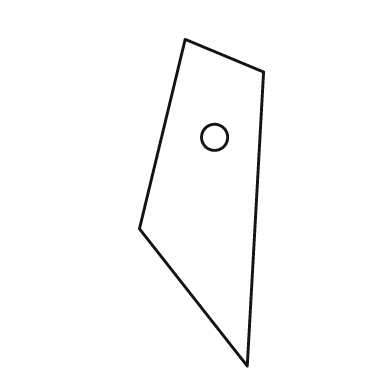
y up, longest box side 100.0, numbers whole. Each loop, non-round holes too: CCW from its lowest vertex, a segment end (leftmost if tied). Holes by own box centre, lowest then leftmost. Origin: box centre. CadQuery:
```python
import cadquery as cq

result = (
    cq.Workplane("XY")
    .moveTo(14.0, -50.0)
    .lineTo(19.0, 40.0)
    .lineTo(-5.0, 50.0)
    .lineTo(-19.0, -8.0)
    .close()
    .moveTo(4.0, 20.0)
    .circle(4.0)
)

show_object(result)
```